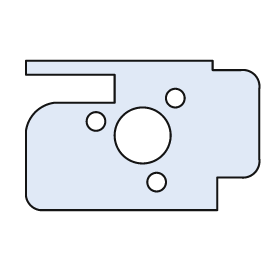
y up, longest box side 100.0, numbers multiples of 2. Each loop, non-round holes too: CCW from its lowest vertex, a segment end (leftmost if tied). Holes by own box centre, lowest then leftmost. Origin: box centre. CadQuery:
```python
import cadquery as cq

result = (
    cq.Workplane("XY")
    .moveTo(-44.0, -32.0)
    .lineTo(32.0, -32.0)
    .lineTo(32.0, -18.0)
    .lineTo(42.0, -18.0)
    .threePointArc((48.0, -16.0), (50.0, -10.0))
    .lineTo(50.0, 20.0)
    .threePointArc((48.0, 26.0), (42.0, 28.0))
    .lineTo(30.0, 28.0)
    .lineTo(30.0, 32.0)
    .lineTo(-50.0, 32.0)
    .lineTo(-50.0, 26.0)
    .lineTo(-12.0, 26.0)
    .lineTo(-12.0, 14.0)
    .lineTo(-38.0, 14.0)
    .threePointArc((-46.0, 10.0), (-50.0, 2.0))
    .lineTo(-50.0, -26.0)
    .threePointArc((-48.0, -30.0), (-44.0, -32.0))
    .close()
    .moveTo(6.0, -20.0)
    .circle(4.0)
    .moveTo(0.0, 0.0)
    .circle(12.0)
    .moveTo(-20.0, 6.0)
    .circle(4.0)
    .moveTo(14.0, 16.0)
    .circle(4.0)
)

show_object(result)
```